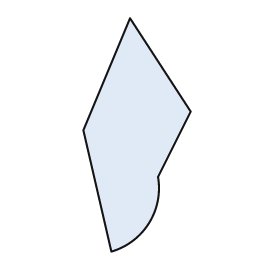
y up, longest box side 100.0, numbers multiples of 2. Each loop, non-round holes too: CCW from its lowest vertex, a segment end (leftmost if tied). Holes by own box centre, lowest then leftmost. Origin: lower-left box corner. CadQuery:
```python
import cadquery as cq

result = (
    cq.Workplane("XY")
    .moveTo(12.0, 0.0)
    .threePointArc((28.0, 12.0), (32.0, 32.0))
    .lineTo(46.0, 60.0)
    .lineTo(20.0, 100.0)
    .lineTo(0.0, 52.0)
    .close()
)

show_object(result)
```